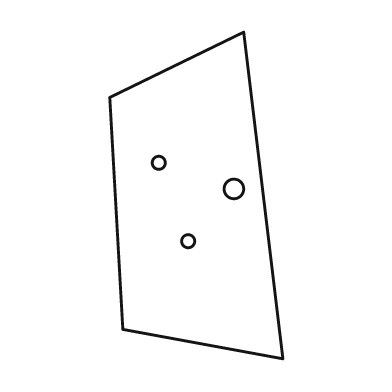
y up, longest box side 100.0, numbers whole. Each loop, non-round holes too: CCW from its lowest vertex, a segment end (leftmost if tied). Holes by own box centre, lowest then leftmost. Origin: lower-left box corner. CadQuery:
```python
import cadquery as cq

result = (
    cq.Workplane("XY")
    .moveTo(53.0, 0.0)
    .lineTo(41.0, 100.0)
    .lineTo(0.0, 80.0)
    .lineTo(4.0, 9.0)
    .close()
    .moveTo(24.0, 36.0)
    .circle(2.0)
    .moveTo(38.0, 52.0)
    .circle(3.0)
    .moveTo(15.0, 60.0)
    .circle(2.0)
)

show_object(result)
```